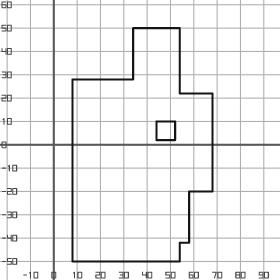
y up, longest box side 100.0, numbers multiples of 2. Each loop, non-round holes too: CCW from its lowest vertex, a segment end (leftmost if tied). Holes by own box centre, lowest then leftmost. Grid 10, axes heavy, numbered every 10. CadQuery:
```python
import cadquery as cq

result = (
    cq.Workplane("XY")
    .moveTo(8.0, -50.0)
    .lineTo(54.0, -50.0)
    .lineTo(54.0, -42.0)
    .lineTo(58.0, -42.0)
    .lineTo(58.0, -20.0)
    .lineTo(68.0, -20.0)
    .lineTo(68.0, 22.0)
    .lineTo(54.0, 22.0)
    .lineTo(54.0, 50.0)
    .lineTo(34.0, 50.0)
    .lineTo(34.0, 28.0)
    .lineTo(8.0, 28.0)
    .close()
    .moveTo(44.0, 2.0)
    .lineTo(52.0, 2.0)
    .lineTo(52.0, 10.0)
    .lineTo(44.0, 10.0)
    .close()
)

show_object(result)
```